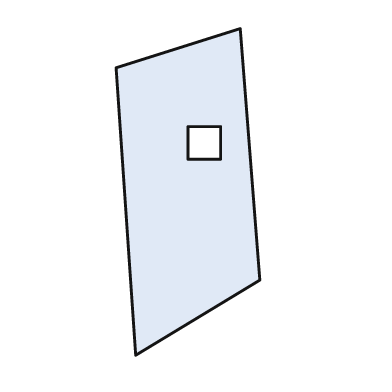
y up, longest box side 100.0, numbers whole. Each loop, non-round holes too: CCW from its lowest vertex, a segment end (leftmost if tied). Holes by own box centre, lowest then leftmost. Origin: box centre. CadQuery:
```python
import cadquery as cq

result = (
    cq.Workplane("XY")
    .moveTo(-16.0, -50.0)
    .lineTo(22.0, -27.0)
    .lineTo(16.0, 50.0)
    .lineTo(-22.0, 38.0)
    .close()
    .moveTo(0.0, 10.0)
    .lineTo(10.0, 10.0)
    .lineTo(10.0, 20.0)
    .lineTo(0.0, 20.0)
    .close()
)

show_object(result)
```